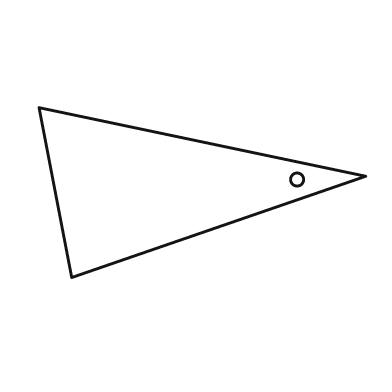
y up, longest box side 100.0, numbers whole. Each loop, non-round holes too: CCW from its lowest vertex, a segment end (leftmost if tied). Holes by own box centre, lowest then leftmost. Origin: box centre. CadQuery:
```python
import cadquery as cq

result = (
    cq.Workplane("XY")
    .moveTo(-40.0, -26.0)
    .lineTo(50.0, 5.0)
    .lineTo(-50.0, 26.0)
    .close()
    .moveTo(29.0, 4.0)
    .circle(2.0)
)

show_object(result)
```